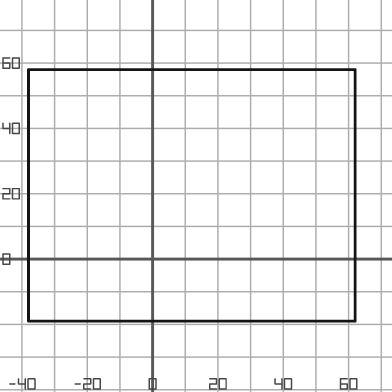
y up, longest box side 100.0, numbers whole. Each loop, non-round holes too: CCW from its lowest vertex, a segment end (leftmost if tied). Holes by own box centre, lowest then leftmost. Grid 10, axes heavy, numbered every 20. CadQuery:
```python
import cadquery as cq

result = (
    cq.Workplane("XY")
    .moveTo(-38.0, -19.0)
    .lineTo(62.0, -19.0)
    .lineTo(62.0, 58.0)
    .lineTo(-38.0, 58.0)
    .close()
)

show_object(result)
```